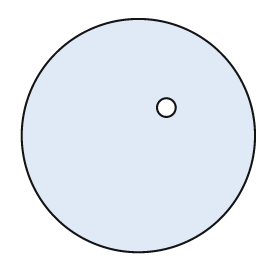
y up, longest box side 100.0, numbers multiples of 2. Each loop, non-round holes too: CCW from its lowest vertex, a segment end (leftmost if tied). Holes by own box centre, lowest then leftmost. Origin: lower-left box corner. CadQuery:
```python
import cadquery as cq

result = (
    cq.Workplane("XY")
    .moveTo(50.0, 50.0)
    .circle(50.0)
    .moveTo(62.0, 62.0)
    .circle(4.0)
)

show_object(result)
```